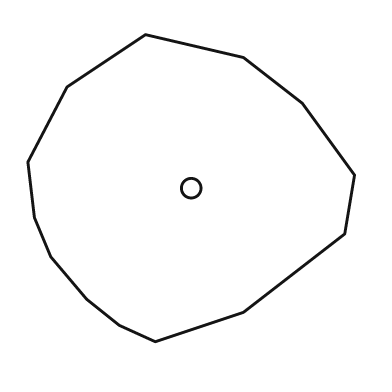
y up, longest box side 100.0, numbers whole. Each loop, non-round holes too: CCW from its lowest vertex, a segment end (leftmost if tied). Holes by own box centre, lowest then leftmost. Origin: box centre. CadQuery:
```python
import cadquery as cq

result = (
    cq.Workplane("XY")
    .moveTo(-11.0, -47.0)
    .lineTo(16.0, -38.0)
    .lineTo(47.0, -14.0)
    .lineTo(50.0, 4.0)
    .lineTo(34.0, 26.0)
    .lineTo(16.0, 40.0)
    .lineTo(-14.0, 47.0)
    .lineTo(-38.0, 31.0)
    .lineTo(-50.0, 8.0)
    .lineTo(-48.0, -9.0)
    .lineTo(-43.0, -21.0)
    .lineTo(-32.0, -34.0)
    .lineTo(-22.0, -42.0)
    .close()
    .moveTo(0.0, 0.0)
    .circle(3.0)
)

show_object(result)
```